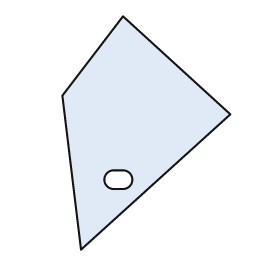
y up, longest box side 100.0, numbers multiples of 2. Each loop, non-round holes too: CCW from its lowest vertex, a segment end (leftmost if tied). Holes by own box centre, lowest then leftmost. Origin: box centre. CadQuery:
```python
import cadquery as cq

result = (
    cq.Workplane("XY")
    .moveTo(-28.0, -50.0)
    .lineTo(36.0, 8.0)
    .lineTo(-10.0, 50.0)
    .lineTo(-36.0, 16.0)
    .close()
    .moveTo(-14.0, -24.0)
    .lineTo(-10.0, -24.0)
    .threePointArc((-6.0, -20.0), (-10.0, -16.0))
    .lineTo(-14.0, -16.0)
    .threePointArc((-18.0, -20.0), (-14.0, -24.0))
    .close()
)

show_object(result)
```